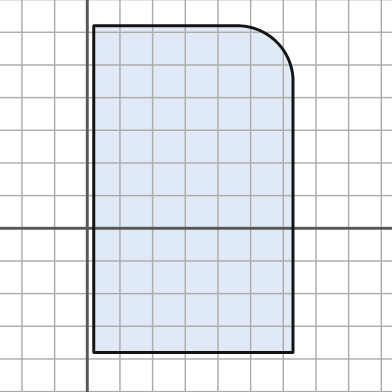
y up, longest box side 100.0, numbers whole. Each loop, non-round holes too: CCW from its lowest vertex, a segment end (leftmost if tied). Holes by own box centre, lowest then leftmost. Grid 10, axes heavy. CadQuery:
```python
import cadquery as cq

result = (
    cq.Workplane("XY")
    .moveTo(2.0, -38.0)
    .lineTo(63.0, -38.0)
    .lineTo(63.0, 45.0)
    .threePointArc((58.0, 57.0), (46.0, 62.0))
    .lineTo(2.0, 62.0)
    .close()
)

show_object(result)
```